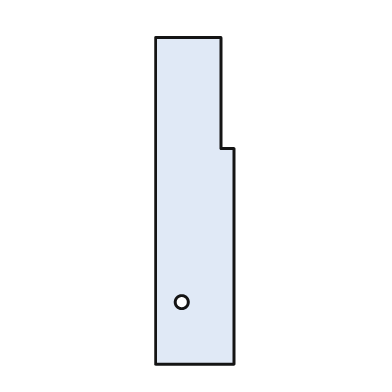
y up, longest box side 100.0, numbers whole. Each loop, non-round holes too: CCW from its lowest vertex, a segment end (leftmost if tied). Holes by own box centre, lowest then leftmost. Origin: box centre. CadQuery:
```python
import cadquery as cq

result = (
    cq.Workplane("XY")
    .moveTo(-12.0, -50.0)
    .lineTo(12.0, -50.0)
    .lineTo(12.0, 16.0)
    .lineTo(8.0, 16.0)
    .lineTo(8.0, 50.0)
    .lineTo(-12.0, 50.0)
    .close()
    .moveTo(-4.0, -31.0)
    .circle(2.0)
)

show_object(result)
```